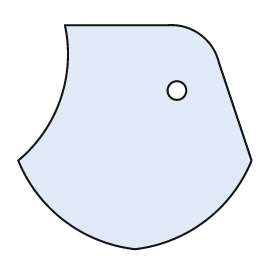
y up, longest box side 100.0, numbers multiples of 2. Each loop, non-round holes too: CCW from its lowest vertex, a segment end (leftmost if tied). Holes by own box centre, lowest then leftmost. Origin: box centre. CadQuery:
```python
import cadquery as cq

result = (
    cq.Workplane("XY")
    .moveTo(0.0, -48.0)
    .threePointArc((30.0, -36.0), (50.0, -10.0))
    .lineTo(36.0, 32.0)
    .threePointArc((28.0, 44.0), (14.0, 48.0))
    .lineTo(-30.0, 48.0)
    .threePointArc((-32.0, 16.0), (-50.0, -10.0))
    .threePointArc((-30.0, -36.0), (0.0, -48.0))
    .close()
    .moveTo(18.0, 20.0)
    .circle(4.0)
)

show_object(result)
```